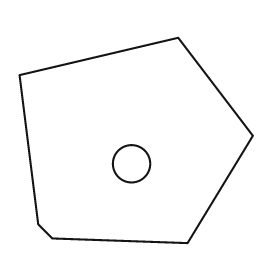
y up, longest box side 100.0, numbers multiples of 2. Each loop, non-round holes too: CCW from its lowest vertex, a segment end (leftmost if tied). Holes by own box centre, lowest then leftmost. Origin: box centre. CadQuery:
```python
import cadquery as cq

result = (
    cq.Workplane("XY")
    .moveTo(22.0, -44.0)
    .lineTo(50.0, 2.0)
    .lineTo(18.0, 44.0)
    .lineTo(-50.0, 28.0)
    .lineTo(-42.0, -36.0)
    .lineTo(-36.0, -42.0)
    .close()
    .moveTo(-2.0, -10.0)
    .circle(8.0)
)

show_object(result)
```